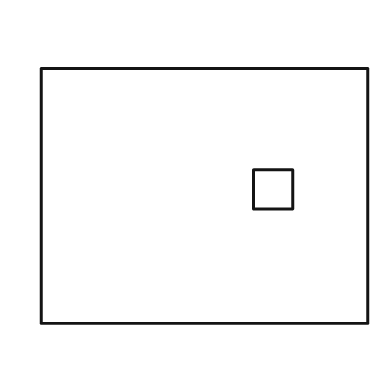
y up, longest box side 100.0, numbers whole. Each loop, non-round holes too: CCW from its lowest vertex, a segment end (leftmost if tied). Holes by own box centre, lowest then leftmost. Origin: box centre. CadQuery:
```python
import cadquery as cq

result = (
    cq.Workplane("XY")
    .moveTo(-50.0, -39.0)
    .lineTo(50.0, -39.0)
    .lineTo(50.0, 39.0)
    .lineTo(-50.0, 39.0)
    .close()
    .moveTo(15.0, -4.0)
    .lineTo(27.0, -4.0)
    .lineTo(27.0, 8.0)
    .lineTo(15.0, 8.0)
    .close()
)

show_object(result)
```